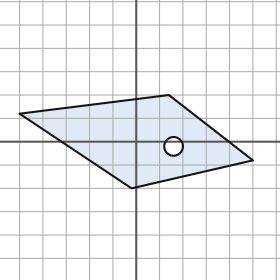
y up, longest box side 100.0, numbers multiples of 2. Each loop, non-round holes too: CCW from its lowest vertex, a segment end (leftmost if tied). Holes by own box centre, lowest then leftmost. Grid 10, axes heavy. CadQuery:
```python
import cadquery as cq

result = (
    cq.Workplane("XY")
    .moveTo(-2.0, -20.0)
    .lineTo(50.0, -8.0)
    .lineTo(14.0, 20.0)
    .lineTo(-50.0, 12.0)
    .close()
    .moveTo(16.0, -2.0)
    .circle(4.0)
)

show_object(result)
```